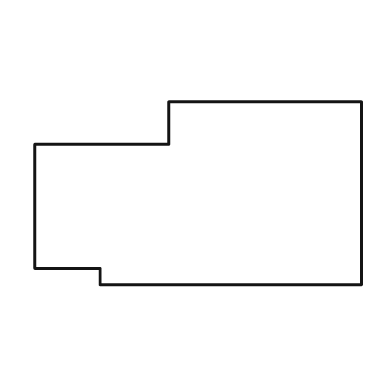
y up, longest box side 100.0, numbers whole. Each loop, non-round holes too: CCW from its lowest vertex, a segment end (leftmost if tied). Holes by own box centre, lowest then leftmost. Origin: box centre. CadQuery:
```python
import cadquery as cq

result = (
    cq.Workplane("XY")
    .moveTo(-30.0, -28.0)
    .lineTo(50.0, -28.0)
    .lineTo(50.0, 28.0)
    .lineTo(-9.0, 28.0)
    .lineTo(-9.0, 15.0)
    .lineTo(-50.0, 15.0)
    .lineTo(-50.0, -23.0)
    .lineTo(-30.0, -23.0)
    .close()
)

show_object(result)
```